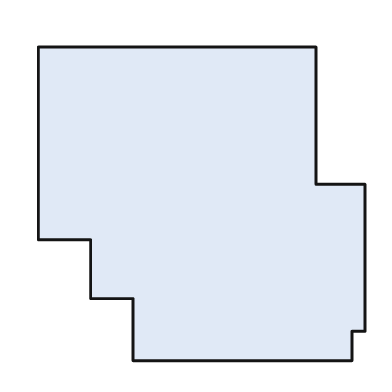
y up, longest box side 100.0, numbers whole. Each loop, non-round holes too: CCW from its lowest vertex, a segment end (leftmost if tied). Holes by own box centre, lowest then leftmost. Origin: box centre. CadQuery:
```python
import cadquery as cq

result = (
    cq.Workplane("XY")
    .moveTo(-21.0, -48.0)
    .lineTo(46.0, -48.0)
    .lineTo(46.0, -39.0)
    .lineTo(50.0, -39.0)
    .lineTo(50.0, 6.0)
    .lineTo(35.0, 6.0)
    .lineTo(35.0, 48.0)
    .lineTo(-50.0, 48.0)
    .lineTo(-50.0, -11.0)
    .lineTo(-34.0, -11.0)
    .lineTo(-34.0, -29.0)
    .lineTo(-21.0, -29.0)
    .close()
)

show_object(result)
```